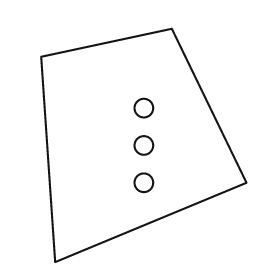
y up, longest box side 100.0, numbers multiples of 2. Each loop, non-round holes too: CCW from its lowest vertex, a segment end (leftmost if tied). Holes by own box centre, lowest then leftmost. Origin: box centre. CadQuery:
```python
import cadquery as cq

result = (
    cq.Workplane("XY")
    .moveTo(-38.0, -50.0)
    .lineTo(44.0, -16.0)
    .lineTo(12.0, 50.0)
    .lineTo(-44.0, 38.0)
    .close()
    .moveTo(0.0, -16.0)
    .circle(4.0)
    .moveTo(0.0, 0.0)
    .circle(4.0)
    .moveTo(0.0, 16.0)
    .circle(4.0)
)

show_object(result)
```